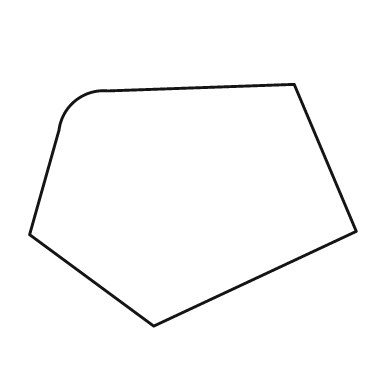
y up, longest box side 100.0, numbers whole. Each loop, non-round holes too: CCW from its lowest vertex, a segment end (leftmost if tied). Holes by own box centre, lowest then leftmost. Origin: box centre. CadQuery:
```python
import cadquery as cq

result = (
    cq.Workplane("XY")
    .moveTo(-12.0, -37.0)
    .lineTo(50.0, -8.0)
    .lineTo(31.0, 37.0)
    .lineTo(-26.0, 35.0)
    .threePointArc((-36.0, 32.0), (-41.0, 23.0))
    .lineTo(-50.0, -9.0)
    .close()
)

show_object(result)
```